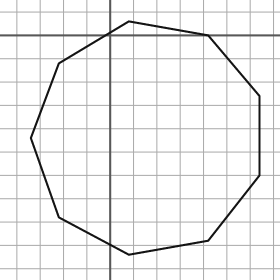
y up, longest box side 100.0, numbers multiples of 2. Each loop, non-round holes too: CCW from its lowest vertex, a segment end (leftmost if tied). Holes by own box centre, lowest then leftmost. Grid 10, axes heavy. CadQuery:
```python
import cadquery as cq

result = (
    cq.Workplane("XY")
    .moveTo(8.0, -94.0)
    .lineTo(42.0, -88.0)
    .lineTo(64.0, -60.0)
    .lineTo(64.0, -26.0)
    .lineTo(42.0, 0.0)
    .lineTo(8.0, 6.0)
    .lineTo(-22.0, -12.0)
    .lineTo(-34.0, -44.0)
    .lineTo(-22.0, -78.0)
    .close()
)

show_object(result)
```